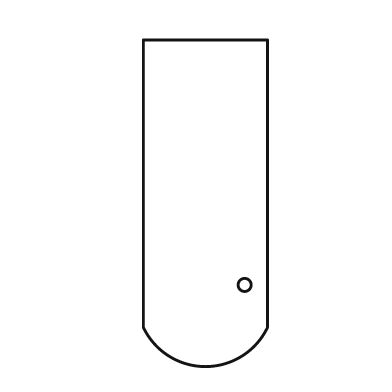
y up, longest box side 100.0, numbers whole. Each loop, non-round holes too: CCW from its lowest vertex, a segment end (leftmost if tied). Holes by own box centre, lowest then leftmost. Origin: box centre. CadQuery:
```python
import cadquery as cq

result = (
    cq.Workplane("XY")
    .moveTo(-19.0, -38.0)
    .threePointArc((0.0, -50.0), (19.0, -38.0))
    .lineTo(19.0, 50.0)
    .lineTo(-19.0, 50.0)
    .close()
    .moveTo(12.0, -25.0)
    .circle(2.0)
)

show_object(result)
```